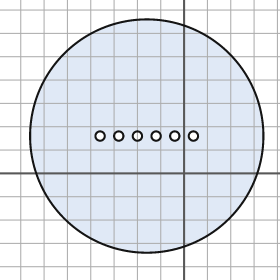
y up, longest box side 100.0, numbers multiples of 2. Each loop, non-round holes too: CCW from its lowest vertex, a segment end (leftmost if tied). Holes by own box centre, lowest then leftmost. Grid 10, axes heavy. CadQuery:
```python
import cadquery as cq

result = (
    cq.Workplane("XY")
    .moveTo(-16.0, 16.0)
    .circle(50.0)
    .moveTo(-36.0, 16.0)
    .circle(2.0)
    .moveTo(-28.0, 16.0)
    .circle(2.0)
    .moveTo(-20.0, 16.0)
    .circle(2.0)
    .moveTo(-12.0, 16.0)
    .circle(2.0)
    .moveTo(-4.0, 16.0)
    .circle(2.0)
    .moveTo(4.0, 16.0)
    .circle(2.0)
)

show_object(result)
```